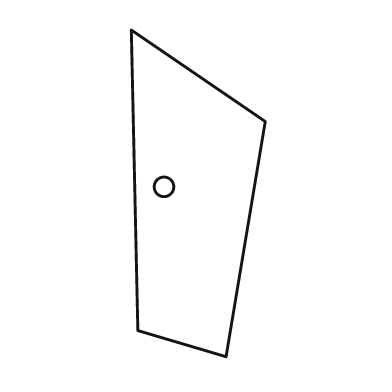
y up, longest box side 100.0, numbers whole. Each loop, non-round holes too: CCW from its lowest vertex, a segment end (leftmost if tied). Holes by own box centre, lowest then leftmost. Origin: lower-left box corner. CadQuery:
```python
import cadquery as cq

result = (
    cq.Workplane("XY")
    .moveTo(29.0, 0.0)
    .lineTo(41.0, 72.0)
    .lineTo(0.0, 100.0)
    .lineTo(2.0, 8.0)
    .close()
    .moveTo(10.0, 52.0)
    .circle(3.0)
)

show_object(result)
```